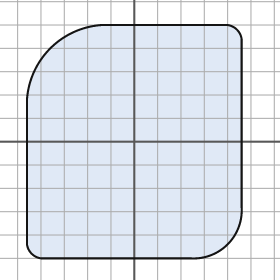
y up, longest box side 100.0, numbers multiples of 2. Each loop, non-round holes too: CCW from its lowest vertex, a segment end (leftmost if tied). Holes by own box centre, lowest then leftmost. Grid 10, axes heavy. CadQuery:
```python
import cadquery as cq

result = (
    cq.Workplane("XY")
    .moveTo(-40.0, -50.0)
    .lineTo(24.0, -50.0)
    .threePointArc((40.0, -44.0), (46.0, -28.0))
    .lineTo(46.0, 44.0)
    .threePointArc((44.0, 48.0), (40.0, 50.0))
    .lineTo(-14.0, 50.0)
    .threePointArc((-36.0, 40.0), (-46.0, 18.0))
    .lineTo(-46.0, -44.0)
    .threePointArc((-44.0, -48.0), (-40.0, -50.0))
    .close()
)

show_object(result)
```